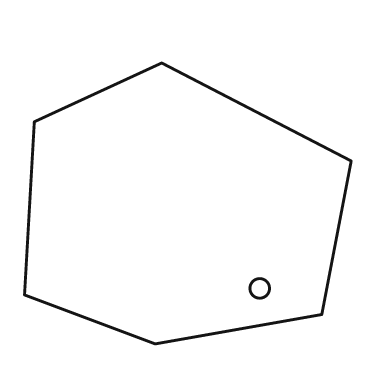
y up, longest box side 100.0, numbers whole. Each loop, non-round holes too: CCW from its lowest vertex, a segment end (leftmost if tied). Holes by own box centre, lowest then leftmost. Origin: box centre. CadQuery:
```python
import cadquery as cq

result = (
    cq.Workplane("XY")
    .moveTo(-10.0, -43.0)
    .lineTo(41.0, -34.0)
    .lineTo(50.0, 13.0)
    .lineTo(-8.0, 43.0)
    .lineTo(-47.0, 25.0)
    .lineTo(-50.0, -28.0)
    .close()
    .moveTo(22.0, -26.0)
    .circle(3.0)
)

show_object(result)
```